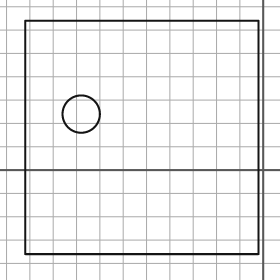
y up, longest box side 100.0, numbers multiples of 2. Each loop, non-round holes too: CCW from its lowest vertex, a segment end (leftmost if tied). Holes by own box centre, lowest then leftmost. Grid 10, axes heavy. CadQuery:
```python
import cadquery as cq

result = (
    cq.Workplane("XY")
    .moveTo(-102.0, -36.0)
    .lineTo(-2.0, -36.0)
    .lineTo(-2.0, 64.0)
    .lineTo(-102.0, 64.0)
    .close()
    .moveTo(-78.0, 24.0)
    .circle(8.0)
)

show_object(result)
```